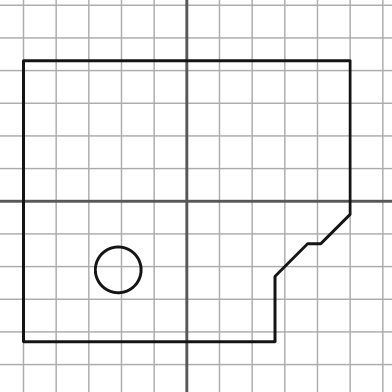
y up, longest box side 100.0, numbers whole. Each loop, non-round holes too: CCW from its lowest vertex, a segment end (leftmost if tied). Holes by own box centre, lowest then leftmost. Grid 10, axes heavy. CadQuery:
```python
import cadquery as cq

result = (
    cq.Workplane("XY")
    .moveTo(-50.0, -43.0)
    .lineTo(27.0, -43.0)
    .lineTo(27.0, -23.0)
    .lineTo(37.0, -13.0)
    .lineTo(41.0, -13.0)
    .lineTo(50.0, -4.0)
    .lineTo(50.0, 43.0)
    .lineTo(-50.0, 43.0)
    .close()
    .moveTo(-21.0, -21.0)
    .circle(7.0)
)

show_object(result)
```